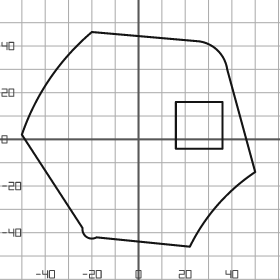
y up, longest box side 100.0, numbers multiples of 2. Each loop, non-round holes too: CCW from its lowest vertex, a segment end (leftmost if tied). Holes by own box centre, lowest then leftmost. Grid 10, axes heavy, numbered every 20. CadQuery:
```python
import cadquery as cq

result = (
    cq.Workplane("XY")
    .moveTo(22.0, -46.0)
    .threePointArc((34.0, -28.0), (50.0, -14.0))
    .lineTo(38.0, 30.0)
    .threePointArc((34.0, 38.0), (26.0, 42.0))
    .lineTo(-20.0, 46.0)
    .threePointArc((-38.0, 26.0), (-50.0, 2.0))
    .lineTo(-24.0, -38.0)
    .threePointArc((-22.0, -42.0), (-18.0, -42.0))
    .close()
    .moveTo(16.0, -4.0)
    .lineTo(36.0, -4.0)
    .lineTo(36.0, 16.0)
    .lineTo(16.0, 16.0)
    .close()
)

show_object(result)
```